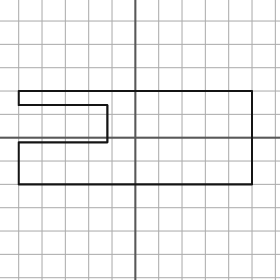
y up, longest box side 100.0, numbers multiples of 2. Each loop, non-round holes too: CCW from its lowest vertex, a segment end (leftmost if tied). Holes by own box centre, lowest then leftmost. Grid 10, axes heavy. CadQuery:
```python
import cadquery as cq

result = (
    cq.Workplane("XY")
    .moveTo(-50.0, -20.0)
    .lineTo(50.0, -20.0)
    .lineTo(50.0, 20.0)
    .lineTo(-50.0, 20.0)
    .lineTo(-50.0, 14.0)
    .lineTo(-12.0, 14.0)
    .lineTo(-12.0, -2.0)
    .lineTo(-50.0, -2.0)
    .close()
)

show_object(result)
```